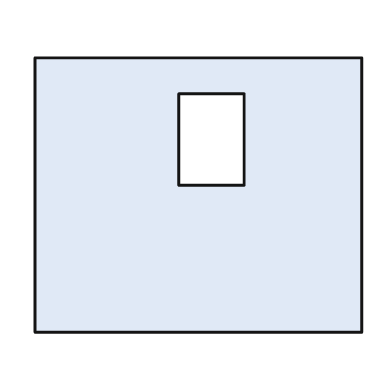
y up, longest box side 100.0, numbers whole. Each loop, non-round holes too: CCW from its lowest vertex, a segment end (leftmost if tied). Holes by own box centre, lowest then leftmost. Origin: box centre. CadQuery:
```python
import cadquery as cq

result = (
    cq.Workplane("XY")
    .moveTo(-50.0, -42.0)
    .lineTo(50.0, -42.0)
    .lineTo(50.0, 42.0)
    .lineTo(-50.0, 42.0)
    .close()
    .moveTo(-6.0, 3.0)
    .lineTo(14.0, 3.0)
    .lineTo(14.0, 31.0)
    .lineTo(-6.0, 31.0)
    .close()
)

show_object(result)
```